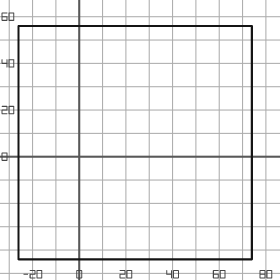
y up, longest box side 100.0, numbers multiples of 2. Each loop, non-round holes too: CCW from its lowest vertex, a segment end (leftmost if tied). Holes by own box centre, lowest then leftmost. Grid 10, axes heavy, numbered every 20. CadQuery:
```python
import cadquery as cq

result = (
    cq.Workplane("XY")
    .moveTo(-26.0, -44.0)
    .lineTo(74.0, -44.0)
    .lineTo(74.0, 56.0)
    .lineTo(-26.0, 56.0)
    .close()
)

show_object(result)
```